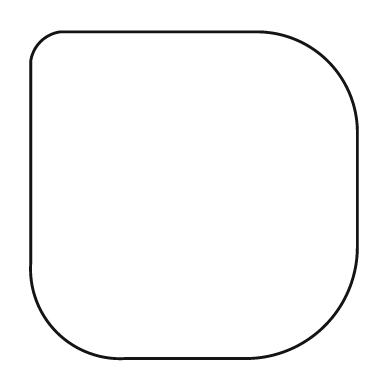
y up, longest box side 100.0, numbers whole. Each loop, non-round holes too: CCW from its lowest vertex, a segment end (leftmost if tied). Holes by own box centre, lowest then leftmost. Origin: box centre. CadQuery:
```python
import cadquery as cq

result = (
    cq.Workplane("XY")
    .moveTo(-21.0, -50.0)
    .lineTo(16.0, -50.0)
    .threePointArc((40.0, -40.0), (50.0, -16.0))
    .lineTo(50.0, 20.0)
    .threePointArc((41.0, 41.0), (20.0, 50.0))
    .lineTo(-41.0, 50.0)
    .threePointArc((-47.0, 47.0), (-50.0, 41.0))
    .lineTo(-50.0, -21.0)
    .threePointArc((-42.0, -42.0), (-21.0, -50.0))
    .close()
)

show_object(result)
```